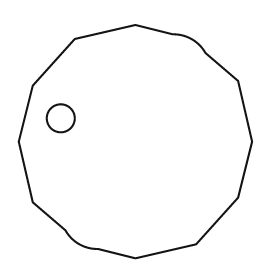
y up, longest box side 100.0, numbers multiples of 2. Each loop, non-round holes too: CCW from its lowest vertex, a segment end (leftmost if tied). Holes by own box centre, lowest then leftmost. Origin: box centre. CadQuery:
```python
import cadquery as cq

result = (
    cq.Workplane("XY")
    .moveTo(0.0, -50.0)
    .lineTo(26.0, -44.0)
    .lineTo(44.0, -24.0)
    .lineTo(50.0, 0.0)
    .lineTo(44.0, 26.0)
    .lineTo(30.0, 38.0)
    .threePointArc((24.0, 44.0), (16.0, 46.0))
    .lineTo(0.0, 50.0)
    .lineTo(-26.0, 44.0)
    .lineTo(-44.0, 24.0)
    .lineTo(-50.0, 0.0)
    .lineTo(-44.0, -26.0)
    .lineTo(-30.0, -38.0)
    .threePointArc((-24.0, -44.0), (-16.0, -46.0))
    .close()
    .moveTo(-32.0, 10.0)
    .circle(6.0)
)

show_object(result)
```